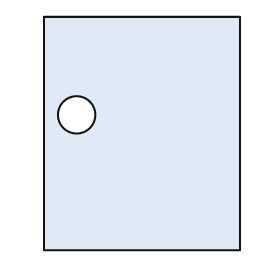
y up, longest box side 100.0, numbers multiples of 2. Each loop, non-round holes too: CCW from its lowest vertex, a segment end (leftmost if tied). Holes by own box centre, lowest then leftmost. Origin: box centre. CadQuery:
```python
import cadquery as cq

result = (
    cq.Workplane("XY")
    .moveTo(-42.0, -50.0)
    .lineTo(42.0, -50.0)
    .lineTo(42.0, 50.0)
    .lineTo(-42.0, 50.0)
    .close()
    .moveTo(-28.0, 8.0)
    .circle(8.0)
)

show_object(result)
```